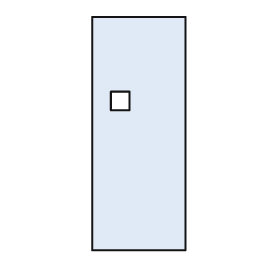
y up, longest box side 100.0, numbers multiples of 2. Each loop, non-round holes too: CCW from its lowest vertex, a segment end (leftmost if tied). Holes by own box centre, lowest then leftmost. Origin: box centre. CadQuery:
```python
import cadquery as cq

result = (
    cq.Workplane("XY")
    .moveTo(-20.0, -50.0)
    .lineTo(20.0, -50.0)
    .lineTo(20.0, 50.0)
    .lineTo(-20.0, 50.0)
    .close()
    .moveTo(-12.0, 10.0)
    .lineTo(-4.0, 10.0)
    .lineTo(-4.0, 18.0)
    .lineTo(-12.0, 18.0)
    .close()
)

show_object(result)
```